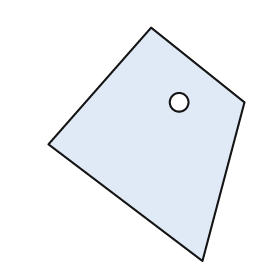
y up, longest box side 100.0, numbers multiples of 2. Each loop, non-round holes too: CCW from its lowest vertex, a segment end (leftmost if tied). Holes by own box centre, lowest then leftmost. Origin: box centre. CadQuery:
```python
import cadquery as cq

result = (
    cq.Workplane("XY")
    .moveTo(24.0, -50.0)
    .lineTo(42.0, 18.0)
    .lineTo(2.0, 50.0)
    .lineTo(-42.0, 0.0)
    .close()
    .moveTo(14.0, 18.0)
    .circle(4.0)
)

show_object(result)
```